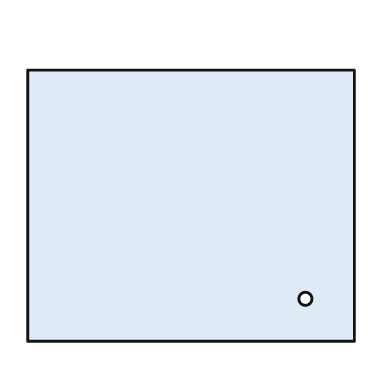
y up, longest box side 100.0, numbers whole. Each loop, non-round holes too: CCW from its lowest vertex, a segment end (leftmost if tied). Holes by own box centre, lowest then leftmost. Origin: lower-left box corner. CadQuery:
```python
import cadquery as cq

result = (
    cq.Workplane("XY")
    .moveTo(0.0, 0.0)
    .lineTo(100.0, 0.0)
    .lineTo(100.0, 83.0)
    .lineTo(0.0, 83.0)
    .close()
    .moveTo(85.0, 13.0)
    .circle(2.0)
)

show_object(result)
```